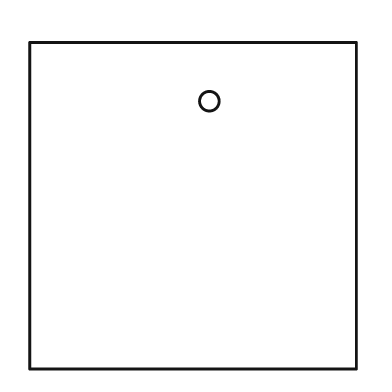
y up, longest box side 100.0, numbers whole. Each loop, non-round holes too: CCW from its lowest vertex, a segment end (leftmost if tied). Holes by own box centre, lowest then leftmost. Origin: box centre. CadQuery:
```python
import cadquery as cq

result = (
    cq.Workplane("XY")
    .moveTo(-50.0, -50.0)
    .lineTo(50.0, -50.0)
    .lineTo(50.0, 50.0)
    .lineTo(-50.0, 50.0)
    .close()
    .moveTo(5.0, 32.0)
    .circle(3.0)
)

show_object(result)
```